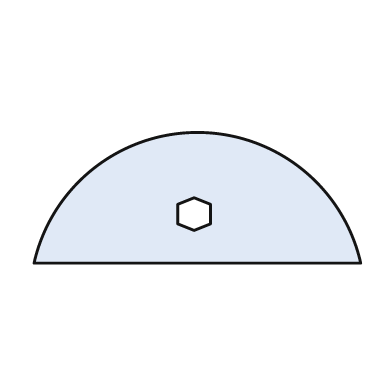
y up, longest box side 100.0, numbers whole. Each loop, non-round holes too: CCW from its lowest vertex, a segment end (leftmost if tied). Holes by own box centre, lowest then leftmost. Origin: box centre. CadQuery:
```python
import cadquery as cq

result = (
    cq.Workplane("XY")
    .moveTo(-50.0, -20.0)
    .lineTo(50.0, -20.0)
    .threePointArc((0.0, 20.0), (-50.0, -20.0))
    .close()
    .moveTo(-1.0, -10.0)
    .lineTo(4.0, -8.0)
    .lineTo(4.0, -2.0)
    .lineTo(-1.0, 0.0)
    .lineTo(-6.0, -2.0)
    .lineTo(-6.0, -8.0)
    .close()
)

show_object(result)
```